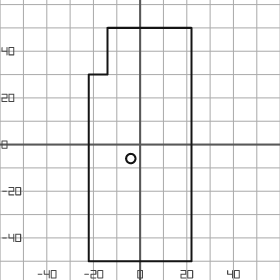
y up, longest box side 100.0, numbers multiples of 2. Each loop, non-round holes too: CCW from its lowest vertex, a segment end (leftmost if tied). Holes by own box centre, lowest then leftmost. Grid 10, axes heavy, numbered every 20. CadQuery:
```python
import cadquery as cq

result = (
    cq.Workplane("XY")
    .moveTo(-22.0, -50.0)
    .lineTo(22.0, -50.0)
    .lineTo(22.0, 50.0)
    .lineTo(-14.0, 50.0)
    .lineTo(-14.0, 30.0)
    .lineTo(-22.0, 30.0)
    .close()
    .moveTo(-4.0, -6.0)
    .circle(2.0)
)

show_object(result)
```